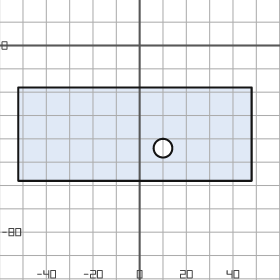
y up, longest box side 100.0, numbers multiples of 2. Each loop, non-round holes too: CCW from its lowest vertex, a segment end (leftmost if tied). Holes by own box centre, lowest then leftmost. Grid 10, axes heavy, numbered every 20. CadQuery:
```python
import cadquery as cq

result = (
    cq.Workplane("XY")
    .moveTo(-52.0, -58.0)
    .lineTo(48.0, -58.0)
    .lineTo(48.0, -18.0)
    .lineTo(-52.0, -18.0)
    .close()
    .moveTo(10.0, -44.0)
    .circle(4.0)
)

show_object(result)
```